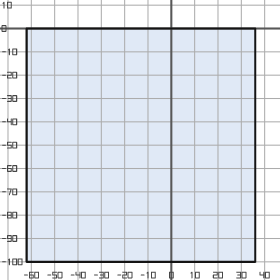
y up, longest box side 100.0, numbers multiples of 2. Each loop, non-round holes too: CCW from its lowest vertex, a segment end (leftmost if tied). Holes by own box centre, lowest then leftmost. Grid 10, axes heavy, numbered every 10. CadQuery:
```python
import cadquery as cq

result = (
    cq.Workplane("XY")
    .moveTo(-62.0, -100.0)
    .lineTo(36.0, -100.0)
    .lineTo(36.0, 0.0)
    .lineTo(-62.0, 0.0)
    .close()
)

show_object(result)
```